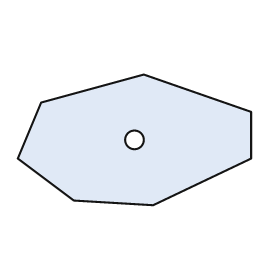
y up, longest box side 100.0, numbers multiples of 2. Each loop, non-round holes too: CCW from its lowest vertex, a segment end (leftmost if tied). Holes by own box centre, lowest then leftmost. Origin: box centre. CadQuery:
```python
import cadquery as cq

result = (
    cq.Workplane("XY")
    .moveTo(8.0, -28.0)
    .lineTo(50.0, -8.0)
    .lineTo(50.0, 12.0)
    .lineTo(4.0, 28.0)
    .lineTo(-40.0, 16.0)
    .lineTo(-50.0, -8.0)
    .lineTo(-26.0, -26.0)
    .close()
    .moveTo(0.0, 0.0)
    .circle(4.0)
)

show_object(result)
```